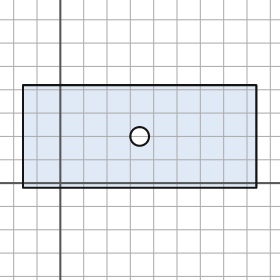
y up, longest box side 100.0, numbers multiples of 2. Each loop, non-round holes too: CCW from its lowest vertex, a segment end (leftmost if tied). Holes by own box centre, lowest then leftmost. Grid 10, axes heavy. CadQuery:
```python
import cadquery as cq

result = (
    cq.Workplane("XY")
    .moveTo(-16.0, -2.0)
    .lineTo(84.0, -2.0)
    .lineTo(84.0, 42.0)
    .lineTo(-16.0, 42.0)
    .close()
    .moveTo(34.0, 20.0)
    .circle(4.0)
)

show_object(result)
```